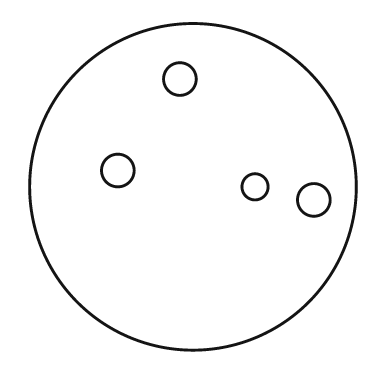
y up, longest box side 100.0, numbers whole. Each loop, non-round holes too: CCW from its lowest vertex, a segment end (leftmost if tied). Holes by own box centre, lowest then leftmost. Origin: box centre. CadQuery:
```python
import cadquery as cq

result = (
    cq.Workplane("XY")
    .moveTo(0.0, 0.0)
    .circle(50.0)
    .moveTo(37.0, -4.0)
    .circle(5.0)
    .moveTo(19.0, 0.0)
    .circle(4.0)
    .moveTo(-23.0, 5.0)
    .circle(5.0)
    .moveTo(-4.0, 33.0)
    .circle(5.0)
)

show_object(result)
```